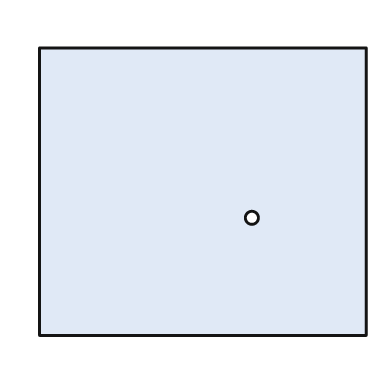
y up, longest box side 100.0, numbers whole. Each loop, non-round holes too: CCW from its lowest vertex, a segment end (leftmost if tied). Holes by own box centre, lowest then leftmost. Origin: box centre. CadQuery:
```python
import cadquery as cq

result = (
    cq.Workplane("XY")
    .moveTo(-50.0, -44.0)
    .lineTo(50.0, -44.0)
    .lineTo(50.0, 44.0)
    .lineTo(-50.0, 44.0)
    .close()
    .moveTo(15.0, -8.0)
    .circle(2.0)
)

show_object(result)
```